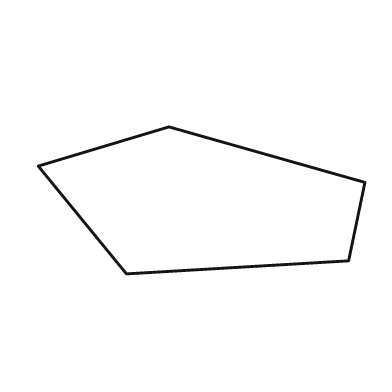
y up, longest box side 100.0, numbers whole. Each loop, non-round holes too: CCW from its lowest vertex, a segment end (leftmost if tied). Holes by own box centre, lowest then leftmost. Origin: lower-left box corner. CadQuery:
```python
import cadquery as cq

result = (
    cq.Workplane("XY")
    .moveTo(27.0, 0.0)
    .lineTo(95.0, 4.0)
    .lineTo(100.0, 28.0)
    .lineTo(40.0, 45.0)
    .lineTo(0.0, 33.0)
    .close()
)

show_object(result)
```